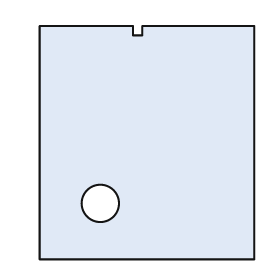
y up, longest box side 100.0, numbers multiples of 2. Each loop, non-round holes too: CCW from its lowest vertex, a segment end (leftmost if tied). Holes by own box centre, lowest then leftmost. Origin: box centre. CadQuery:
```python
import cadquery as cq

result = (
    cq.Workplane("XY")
    .moveTo(-46.0, -50.0)
    .lineTo(46.0, -50.0)
    .lineTo(46.0, 50.0)
    .lineTo(-2.0, 50.0)
    .lineTo(-2.0, 46.0)
    .lineTo(-6.0, 46.0)
    .lineTo(-6.0, 50.0)
    .lineTo(-46.0, 50.0)
    .close()
    .moveTo(-20.0, -26.0)
    .circle(8.0)
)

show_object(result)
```